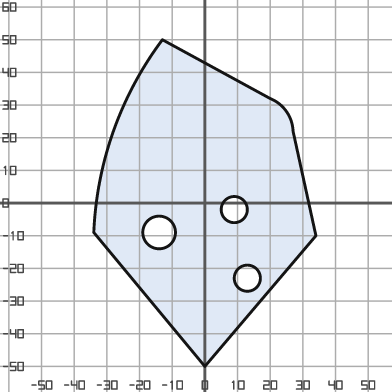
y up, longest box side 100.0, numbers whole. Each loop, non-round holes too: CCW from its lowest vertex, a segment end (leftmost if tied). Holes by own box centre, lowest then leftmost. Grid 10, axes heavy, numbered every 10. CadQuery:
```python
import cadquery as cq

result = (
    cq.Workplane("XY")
    .moveTo(0.0, -50.0)
    .lineTo(34.0, -10.0)
    .lineTo(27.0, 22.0)
    .threePointArc((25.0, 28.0), (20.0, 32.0))
    .lineTo(-13.0, 50.0)
    .threePointArc((-28.0, 22.0), (-34.0, -9.0))
    .close()
    .moveTo(13.0, -23.0)
    .circle(4.0)
    .moveTo(-14.0, -9.0)
    .circle(5.0)
    .moveTo(9.0, -2.0)
    .circle(4.0)
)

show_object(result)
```